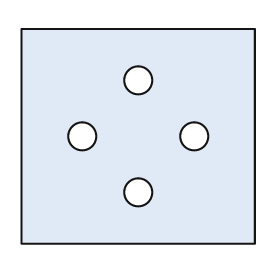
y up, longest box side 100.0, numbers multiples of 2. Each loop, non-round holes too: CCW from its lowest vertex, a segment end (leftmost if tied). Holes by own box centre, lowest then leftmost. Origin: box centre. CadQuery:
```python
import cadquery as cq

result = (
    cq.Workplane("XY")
    .moveTo(-50.0, -46.0)
    .lineTo(50.0, -46.0)
    .lineTo(50.0, 46.0)
    .lineTo(-50.0, 46.0)
    .close()
    .moveTo(0.0, -24.0)
    .circle(6.0)
    .moveTo(-24.0, 0.0)
    .circle(6.0)
    .moveTo(24.0, 0.0)
    .circle(6.0)
    .moveTo(0.0, 24.0)
    .circle(6.0)
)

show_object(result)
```